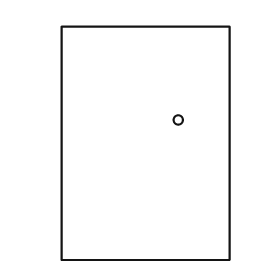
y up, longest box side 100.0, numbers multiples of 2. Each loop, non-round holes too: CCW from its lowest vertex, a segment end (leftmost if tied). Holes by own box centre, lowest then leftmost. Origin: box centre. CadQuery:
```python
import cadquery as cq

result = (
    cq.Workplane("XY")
    .moveTo(-36.0, -50.0)
    .lineTo(36.0, -50.0)
    .lineTo(36.0, 50.0)
    .lineTo(-36.0, 50.0)
    .close()
    .moveTo(14.0, 10.0)
    .circle(2.0)
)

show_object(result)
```